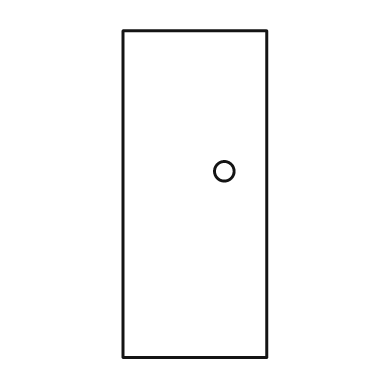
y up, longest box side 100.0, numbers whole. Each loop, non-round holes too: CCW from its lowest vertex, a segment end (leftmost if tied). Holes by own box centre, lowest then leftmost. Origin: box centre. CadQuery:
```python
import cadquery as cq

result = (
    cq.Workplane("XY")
    .moveTo(-22.0, -50.0)
    .lineTo(22.0, -50.0)
    .lineTo(22.0, 50.0)
    .lineTo(-22.0, 50.0)
    .close()
    .moveTo(9.0, 7.0)
    .circle(3.0)
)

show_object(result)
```